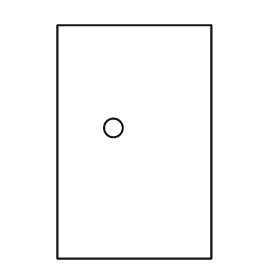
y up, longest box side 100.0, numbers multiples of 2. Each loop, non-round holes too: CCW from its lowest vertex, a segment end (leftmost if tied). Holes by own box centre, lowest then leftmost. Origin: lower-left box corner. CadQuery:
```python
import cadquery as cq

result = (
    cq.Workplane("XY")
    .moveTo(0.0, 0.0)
    .lineTo(66.0, 0.0)
    .lineTo(66.0, 100.0)
    .lineTo(0.0, 100.0)
    .close()
    .moveTo(24.0, 56.0)
    .circle(4.0)
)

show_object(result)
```